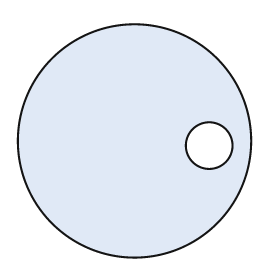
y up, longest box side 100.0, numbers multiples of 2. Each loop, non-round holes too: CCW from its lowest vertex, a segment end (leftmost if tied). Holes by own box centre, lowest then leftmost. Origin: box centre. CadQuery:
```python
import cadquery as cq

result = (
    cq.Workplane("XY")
    .moveTo(0.0, 0.0)
    .circle(50.0)
    .moveTo(32.0, -2.0)
    .circle(10.0)
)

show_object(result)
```